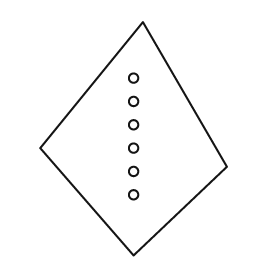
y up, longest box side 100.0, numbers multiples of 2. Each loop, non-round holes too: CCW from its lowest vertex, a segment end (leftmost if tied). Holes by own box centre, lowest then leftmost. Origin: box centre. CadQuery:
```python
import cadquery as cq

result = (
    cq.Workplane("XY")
    .moveTo(0.0, -50.0)
    .lineTo(40.0, -12.0)
    .lineTo(4.0, 50.0)
    .lineTo(-40.0, -4.0)
    .close()
    .moveTo(0.0, -24.0)
    .circle(2.0)
    .moveTo(0.0, -14.0)
    .circle(2.0)
    .moveTo(0.0, -4.0)
    .circle(2.0)
    .moveTo(0.0, 6.0)
    .circle(2.0)
    .moveTo(0.0, 16.0)
    .circle(2.0)
    .moveTo(0.0, 26.0)
    .circle(2.0)
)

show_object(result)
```